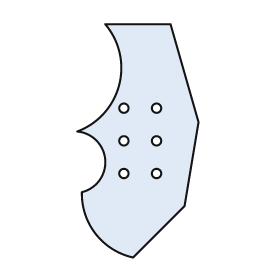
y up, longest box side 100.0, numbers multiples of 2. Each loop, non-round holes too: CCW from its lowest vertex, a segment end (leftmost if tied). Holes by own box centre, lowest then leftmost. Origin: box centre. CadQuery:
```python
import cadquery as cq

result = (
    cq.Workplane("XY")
    .moveTo(-2.0, -50.0)
    .lineTo(20.0, -28.0)
    .lineTo(26.0, 8.0)
    .lineTo(14.0, 50.0)
    .lineTo(-14.0, 50.0)
    .threePointArc((-8.0, 24.0), (-26.0, 4.0))
    .threePointArc((-14.0, -8.0), (-24.0, -22.0))
    .threePointArc((-18.0, -40.0), (-2.0, -50.0))
    .close()
    .moveTo(-6.0, -14.0)
    .circle(2.0)
    .moveTo(8.0, -14.0)
    .circle(2.0)
    .moveTo(-6.0, 0.0)
    .circle(2.0)
    .moveTo(8.0, 0.0)
    .circle(2.0)
    .moveTo(-6.0, 14.0)
    .circle(2.0)
    .moveTo(8.0, 14.0)
    .circle(2.0)
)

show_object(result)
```